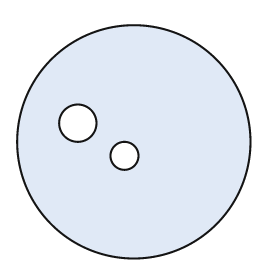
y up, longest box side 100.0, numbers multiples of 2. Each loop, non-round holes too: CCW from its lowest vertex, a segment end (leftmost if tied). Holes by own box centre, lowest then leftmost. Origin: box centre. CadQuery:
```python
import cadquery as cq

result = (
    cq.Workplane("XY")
    .moveTo(0.0, 0.0)
    .circle(50.0)
    .moveTo(-4.0, -6.0)
    .circle(6.0)
    .moveTo(-24.0, 8.0)
    .circle(8.0)
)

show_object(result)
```